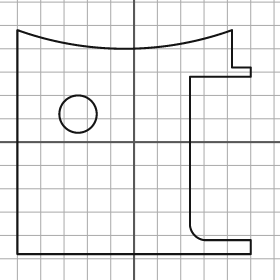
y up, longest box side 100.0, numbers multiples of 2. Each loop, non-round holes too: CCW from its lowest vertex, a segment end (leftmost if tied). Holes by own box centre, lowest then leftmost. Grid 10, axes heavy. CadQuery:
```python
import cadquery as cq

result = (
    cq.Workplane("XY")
    .moveTo(-50.0, -48.0)
    .lineTo(50.0, -48.0)
    .lineTo(50.0, -42.0)
    .lineTo(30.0, -42.0)
    .threePointArc((26.0, -40.0), (24.0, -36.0))
    .lineTo(24.0, 28.0)
    .lineTo(50.0, 28.0)
    .lineTo(50.0, 32.0)
    .lineTo(42.0, 32.0)
    .lineTo(42.0, 48.0)
    .threePointArc((-4.0, 40.0), (-50.0, 48.0))
    .close()
    .moveTo(-24.0, 12.0)
    .circle(8.0)
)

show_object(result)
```